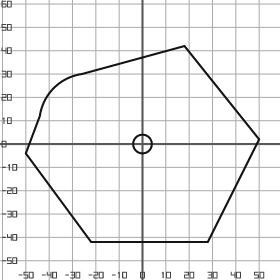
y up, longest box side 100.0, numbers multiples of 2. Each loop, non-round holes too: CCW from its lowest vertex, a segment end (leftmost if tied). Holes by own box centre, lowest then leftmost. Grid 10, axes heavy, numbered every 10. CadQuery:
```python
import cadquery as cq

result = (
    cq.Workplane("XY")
    .moveTo(-22.0, -42.0)
    .lineTo(28.0, -42.0)
    .lineTo(50.0, 2.0)
    .lineTo(18.0, 42.0)
    .lineTo(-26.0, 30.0)
    .threePointArc((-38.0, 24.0), (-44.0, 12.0))
    .lineTo(-50.0, -4.0)
    .close()
    .moveTo(0.0, 0.0)
    .circle(4.0)
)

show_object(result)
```